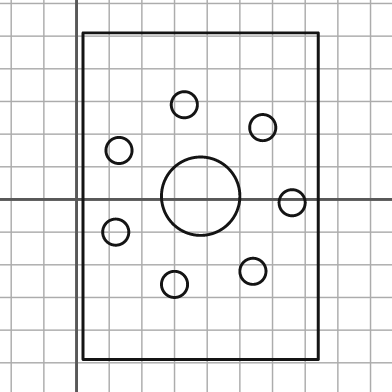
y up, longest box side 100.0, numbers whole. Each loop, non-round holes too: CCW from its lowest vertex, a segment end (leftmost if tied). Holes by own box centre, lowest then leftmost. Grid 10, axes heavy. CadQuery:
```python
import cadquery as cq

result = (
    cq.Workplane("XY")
    .moveTo(2.0, -49.0)
    .lineTo(74.0, -49.0)
    .lineTo(74.0, 51.0)
    .lineTo(2.0, 51.0)
    .close()
    .moveTo(30.0, -26.0)
    .circle(4.0)
    .moveTo(54.0, -22.0)
    .circle(4.0)
    .moveTo(12.0, -10.0)
    .circle(4.0)
    .moveTo(66.0, -1.0)
    .circle(4.0)
    .moveTo(38.0, 1.0)
    .circle(12.0)
    .moveTo(13.0, 15.0)
    .circle(4.0)
    .moveTo(57.0, 22.0)
    .circle(4.0)
    .moveTo(33.0, 29.0)
    .circle(4.0)
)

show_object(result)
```